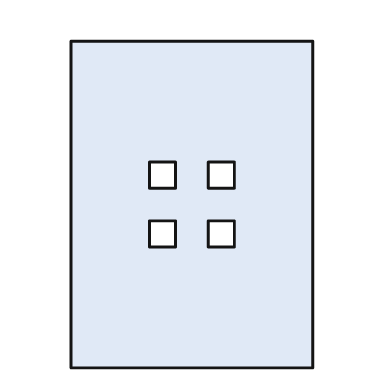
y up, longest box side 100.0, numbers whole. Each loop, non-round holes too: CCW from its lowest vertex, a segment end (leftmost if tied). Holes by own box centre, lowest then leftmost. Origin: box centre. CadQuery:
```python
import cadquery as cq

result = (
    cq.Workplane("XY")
    .moveTo(-37.0, -50.0)
    .lineTo(37.0, -50.0)
    .lineTo(37.0, 50.0)
    .lineTo(-37.0, 50.0)
    .close()
    .moveTo(-13.0, -13.0)
    .lineTo(-5.0, -13.0)
    .lineTo(-5.0, -5.0)
    .lineTo(-13.0, -5.0)
    .close()
    .moveTo(5.0, -13.0)
    .lineTo(13.0, -13.0)
    .lineTo(13.0, -5.0)
    .lineTo(5.0, -5.0)
    .close()
    .moveTo(-13.0, 5.0)
    .lineTo(-5.0, 5.0)
    .lineTo(-5.0, 13.0)
    .lineTo(-13.0, 13.0)
    .close()
    .moveTo(5.0, 5.0)
    .lineTo(13.0, 5.0)
    .lineTo(13.0, 13.0)
    .lineTo(5.0, 13.0)
    .close()
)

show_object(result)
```